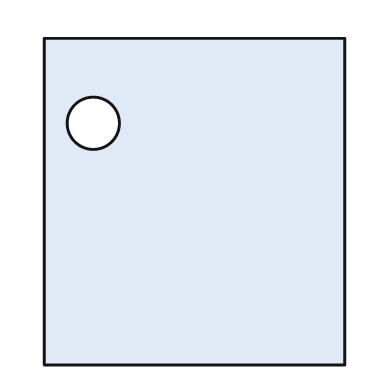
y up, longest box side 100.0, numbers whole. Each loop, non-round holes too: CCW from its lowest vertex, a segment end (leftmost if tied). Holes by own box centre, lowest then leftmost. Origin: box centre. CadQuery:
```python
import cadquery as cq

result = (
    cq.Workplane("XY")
    .moveTo(-46.0, -50.0)
    .lineTo(46.0, -50.0)
    .lineTo(46.0, 50.0)
    .lineTo(-46.0, 50.0)
    .close()
    .moveTo(-31.0, 24.0)
    .circle(8.0)
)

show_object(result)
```